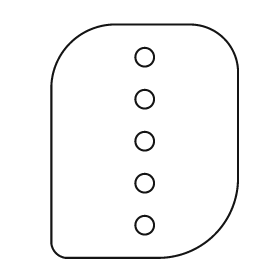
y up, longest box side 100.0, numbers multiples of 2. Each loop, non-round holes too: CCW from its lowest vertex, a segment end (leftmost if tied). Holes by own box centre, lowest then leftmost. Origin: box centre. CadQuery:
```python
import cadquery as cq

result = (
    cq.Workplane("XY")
    .moveTo(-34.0, -50.0)
    .lineTo(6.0, -50.0)
    .threePointArc((30.0, -40.0), (40.0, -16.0))
    .lineTo(40.0, 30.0)
    .threePointArc((34.0, 44.0), (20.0, 50.0))
    .lineTo(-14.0, 50.0)
    .threePointArc((-32.0, 42.0), (-40.0, 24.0))
    .lineTo(-40.0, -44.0)
    .threePointArc((-38.0, -48.0), (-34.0, -50.0))
    .close()
    .moveTo(0.0, -36.0)
    .circle(4.0)
    .moveTo(0.0, -18.0)
    .circle(4.0)
    .moveTo(0.0, 0.0)
    .circle(4.0)
    .moveTo(0.0, 18.0)
    .circle(4.0)
    .moveTo(0.0, 36.0)
    .circle(4.0)
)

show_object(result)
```